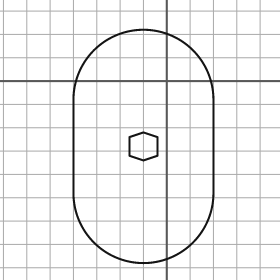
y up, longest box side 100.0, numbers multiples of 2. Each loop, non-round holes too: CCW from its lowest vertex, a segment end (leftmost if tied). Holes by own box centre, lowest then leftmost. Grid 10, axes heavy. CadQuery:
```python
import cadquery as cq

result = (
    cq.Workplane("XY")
    .moveTo(-40.0, -48.0)
    .threePointArc((-10.0, -78.0), (20.0, -48.0))
    .lineTo(20.0, -8.0)
    .threePointArc((-10.0, 22.0), (-40.0, -8.0))
    .close()
    .moveTo(-10.0, -34.0)
    .lineTo(-4.0, -32.0)
    .lineTo(-4.0, -24.0)
    .lineTo(-10.0, -22.0)
    .lineTo(-16.0, -24.0)
    .lineTo(-16.0, -32.0)
    .close()
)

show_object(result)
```